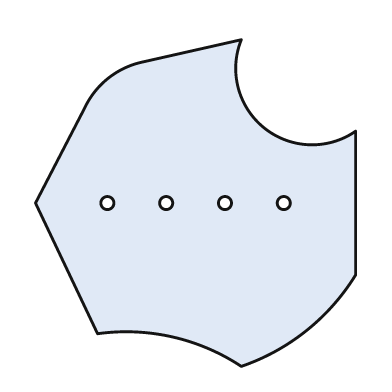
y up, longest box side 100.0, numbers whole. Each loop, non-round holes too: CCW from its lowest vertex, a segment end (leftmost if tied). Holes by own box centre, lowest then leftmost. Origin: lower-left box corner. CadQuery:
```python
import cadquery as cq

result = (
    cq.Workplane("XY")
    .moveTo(63.0, 0.0)
    .threePointArc((83.0, 11.0), (98.0, 28.0))
    .lineTo(98.0, 72.0)
    .threePointArc((70.0, 73.0), (63.0, 100.0))
    .lineTo(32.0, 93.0)
    .threePointArc((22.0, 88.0), (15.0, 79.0))
    .lineTo(0.0, 50.0)
    .lineTo(19.0, 10.0)
    .threePointArc((42.0, 9.0), (63.0, 0.0))
    .close()
    .moveTo(22.0, 50.0)
    .circle(2.0)
    .moveTo(40.0, 50.0)
    .circle(2.0)
    .moveTo(58.0, 50.0)
    .circle(2.0)
    .moveTo(76.0, 50.0)
    .circle(2.0)
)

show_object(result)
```